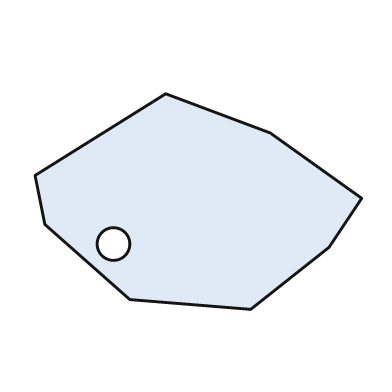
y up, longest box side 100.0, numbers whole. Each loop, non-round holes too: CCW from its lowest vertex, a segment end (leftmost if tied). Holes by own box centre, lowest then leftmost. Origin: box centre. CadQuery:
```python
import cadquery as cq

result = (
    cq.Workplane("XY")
    .moveTo(16.0, -33.0)
    .lineTo(40.0, -14.0)
    .lineTo(50.0, 1.0)
    .lineTo(22.0, 21.0)
    .lineTo(-10.0, 33.0)
    .lineTo(-50.0, 8.0)
    .lineTo(-47.0, -7.0)
    .lineTo(-21.0, -30.0)
    .close()
    .moveTo(-26.0, -13.0)
    .circle(5.0)
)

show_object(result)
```